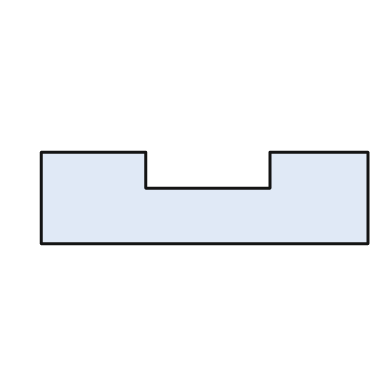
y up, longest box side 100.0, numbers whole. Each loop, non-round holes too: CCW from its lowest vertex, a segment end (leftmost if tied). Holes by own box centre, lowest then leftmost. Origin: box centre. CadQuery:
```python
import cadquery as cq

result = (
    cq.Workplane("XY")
    .moveTo(-50.0, -14.0)
    .lineTo(50.0, -14.0)
    .lineTo(50.0, 14.0)
    .lineTo(20.0, 14.0)
    .lineTo(20.0, 3.0)
    .lineTo(-18.0, 3.0)
    .lineTo(-18.0, 14.0)
    .lineTo(-50.0, 14.0)
    .close()
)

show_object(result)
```